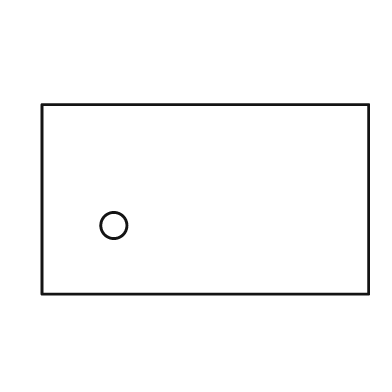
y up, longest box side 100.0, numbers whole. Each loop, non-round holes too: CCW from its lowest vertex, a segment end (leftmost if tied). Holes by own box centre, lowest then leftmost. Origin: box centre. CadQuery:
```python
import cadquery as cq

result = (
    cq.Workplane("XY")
    .moveTo(-50.0, -29.0)
    .lineTo(50.0, -29.0)
    .lineTo(50.0, 29.0)
    .lineTo(-50.0, 29.0)
    .close()
    .moveTo(-28.0, -8.0)
    .circle(4.0)
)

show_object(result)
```